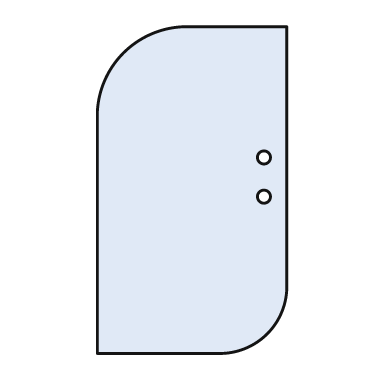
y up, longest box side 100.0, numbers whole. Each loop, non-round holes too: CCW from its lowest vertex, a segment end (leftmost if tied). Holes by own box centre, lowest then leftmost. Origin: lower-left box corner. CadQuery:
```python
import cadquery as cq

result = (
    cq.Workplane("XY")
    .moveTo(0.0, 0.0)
    .lineTo(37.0, 0.0)
    .threePointArc((52.0, 6.0), (58.0, 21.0))
    .lineTo(58.0, 100.0)
    .lineTo(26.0, 100.0)
    .threePointArc((8.0, 92.0), (0.0, 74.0))
    .close()
    .moveTo(51.0, 48.0)
    .circle(2.0)
    .moveTo(51.0, 60.0)
    .circle(2.0)
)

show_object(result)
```